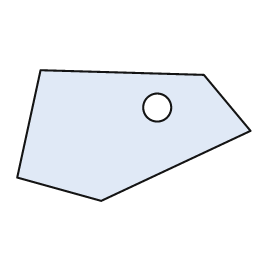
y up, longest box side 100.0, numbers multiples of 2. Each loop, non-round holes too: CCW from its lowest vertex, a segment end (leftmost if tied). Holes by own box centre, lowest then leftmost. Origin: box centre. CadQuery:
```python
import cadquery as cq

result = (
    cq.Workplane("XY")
    .moveTo(-14.0, -28.0)
    .lineTo(50.0, 2.0)
    .lineTo(30.0, 26.0)
    .lineTo(-40.0, 28.0)
    .lineTo(-50.0, -18.0)
    .close()
    .moveTo(10.0, 12.0)
    .circle(6.0)
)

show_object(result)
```